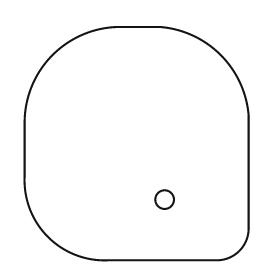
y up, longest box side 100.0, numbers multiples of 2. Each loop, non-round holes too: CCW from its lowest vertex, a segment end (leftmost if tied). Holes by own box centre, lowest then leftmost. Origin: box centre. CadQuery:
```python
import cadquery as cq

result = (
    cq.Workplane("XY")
    .moveTo(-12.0, -50.0)
    .lineTo(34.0, -50.0)
    .threePointArc((44.0, -46.0), (48.0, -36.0))
    .lineTo(48.0, 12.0)
    .threePointArc((36.0, 38.0), (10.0, 50.0))
    .lineTo(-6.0, 50.0)
    .threePointArc((-36.0, 38.0), (-48.0, 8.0))
    .lineTo(-48.0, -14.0)
    .threePointArc((-38.0, -40.0), (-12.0, -50.0))
    .close()
    .moveTo(12.0, -24.0)
    .circle(4.0)
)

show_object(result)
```